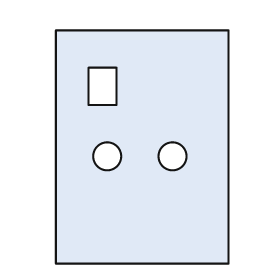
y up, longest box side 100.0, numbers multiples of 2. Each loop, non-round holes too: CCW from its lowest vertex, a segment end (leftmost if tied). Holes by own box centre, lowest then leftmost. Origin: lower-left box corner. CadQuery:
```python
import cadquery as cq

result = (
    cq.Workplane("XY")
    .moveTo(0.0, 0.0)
    .lineTo(74.0, 0.0)
    .lineTo(74.0, 100.0)
    .lineTo(0.0, 100.0)
    .close()
    .moveTo(22.0, 46.0)
    .circle(6.0)
    .moveTo(50.0, 46.0)
    .circle(6.0)
    .moveTo(14.0, 68.0)
    .lineTo(26.0, 68.0)
    .lineTo(26.0, 84.0)
    .lineTo(14.0, 84.0)
    .close()
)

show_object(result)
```